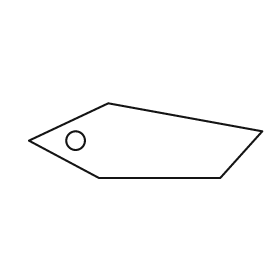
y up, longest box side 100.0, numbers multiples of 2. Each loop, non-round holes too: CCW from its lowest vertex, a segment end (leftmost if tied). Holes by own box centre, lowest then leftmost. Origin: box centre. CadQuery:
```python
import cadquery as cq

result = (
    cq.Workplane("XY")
    .moveTo(-20.0, -16.0)
    .lineTo(32.0, -16.0)
    .lineTo(50.0, 4.0)
    .lineTo(-16.0, 16.0)
    .lineTo(-50.0, 0.0)
    .close()
    .moveTo(-30.0, 0.0)
    .circle(4.0)
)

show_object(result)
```